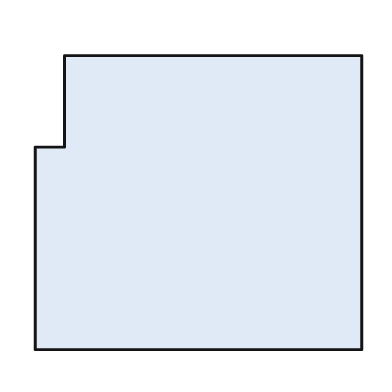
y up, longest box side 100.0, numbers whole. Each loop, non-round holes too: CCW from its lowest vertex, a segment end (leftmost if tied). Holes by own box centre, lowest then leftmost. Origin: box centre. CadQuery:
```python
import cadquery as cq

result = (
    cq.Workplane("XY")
    .moveTo(-50.0, -45.0)
    .lineTo(50.0, -45.0)
    .lineTo(50.0, 45.0)
    .lineTo(-41.0, 45.0)
    .lineTo(-41.0, 17.0)
    .lineTo(-50.0, 17.0)
    .close()
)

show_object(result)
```